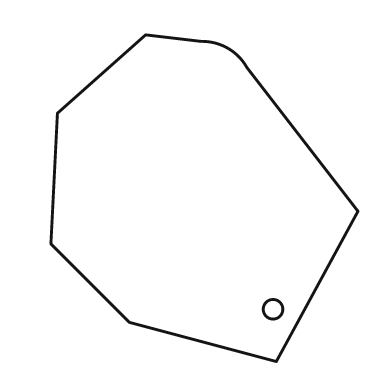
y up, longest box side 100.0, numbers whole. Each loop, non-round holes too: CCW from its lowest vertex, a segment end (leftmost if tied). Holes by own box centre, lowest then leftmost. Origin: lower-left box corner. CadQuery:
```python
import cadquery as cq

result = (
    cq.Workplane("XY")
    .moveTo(69.0, 0.0)
    .lineTo(94.0, 46.0)
    .lineTo(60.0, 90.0)
    .threePointArc((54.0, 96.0), (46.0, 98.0))
    .lineTo(29.0, 100.0)
    .lineTo(2.0, 76.0)
    .lineTo(0.0, 36.0)
    .lineTo(24.0, 12.0)
    .close()
    .moveTo(68.0, 16.0)
    .circle(3.0)
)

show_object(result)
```